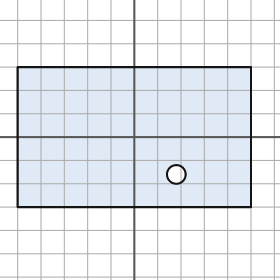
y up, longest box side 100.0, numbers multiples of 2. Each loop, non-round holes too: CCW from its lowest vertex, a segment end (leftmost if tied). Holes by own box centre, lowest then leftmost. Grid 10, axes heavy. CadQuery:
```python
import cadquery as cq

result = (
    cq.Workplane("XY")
    .moveTo(-50.0, -30.0)
    .lineTo(50.0, -30.0)
    .lineTo(50.0, 30.0)
    .lineTo(-50.0, 30.0)
    .close()
    .moveTo(18.0, -16.0)
    .circle(4.0)
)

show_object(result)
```